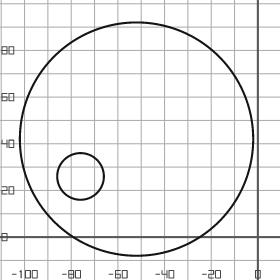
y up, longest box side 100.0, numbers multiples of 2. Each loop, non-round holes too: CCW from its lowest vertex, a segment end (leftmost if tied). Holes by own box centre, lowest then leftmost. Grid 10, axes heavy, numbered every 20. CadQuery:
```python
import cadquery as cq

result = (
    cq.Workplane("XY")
    .moveTo(-52.0, 42.0)
    .circle(50.0)
    .moveTo(-76.0, 26.0)
    .circle(10.0)
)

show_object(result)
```